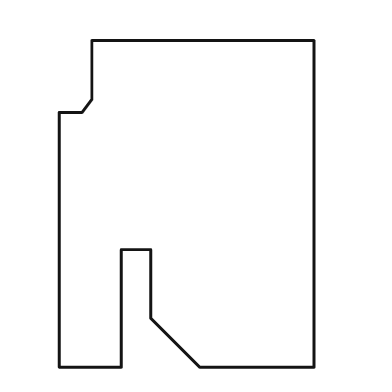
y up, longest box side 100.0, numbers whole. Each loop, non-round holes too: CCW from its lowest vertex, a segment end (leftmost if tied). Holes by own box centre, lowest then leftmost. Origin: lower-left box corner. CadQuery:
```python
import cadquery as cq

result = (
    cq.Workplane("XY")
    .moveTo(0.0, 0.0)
    .lineTo(19.0, 0.0)
    .lineTo(19.0, 36.0)
    .lineTo(28.0, 36.0)
    .lineTo(28.0, 15.0)
    .lineTo(43.0, 0.0)
    .lineTo(78.0, 0.0)
    .lineTo(78.0, 100.0)
    .lineTo(10.0, 100.0)
    .lineTo(10.0, 82.0)
    .lineTo(7.0, 78.0)
    .lineTo(0.0, 78.0)
    .close()
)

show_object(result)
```